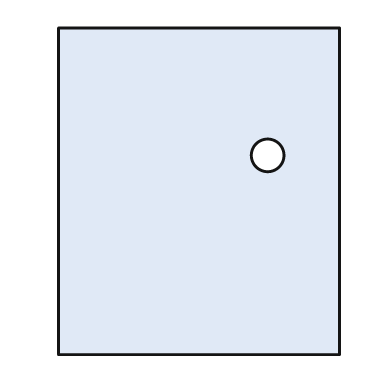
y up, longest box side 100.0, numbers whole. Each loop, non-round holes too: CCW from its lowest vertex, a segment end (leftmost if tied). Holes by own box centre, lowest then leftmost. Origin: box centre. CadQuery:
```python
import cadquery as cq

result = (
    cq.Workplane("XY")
    .moveTo(-43.0, -50.0)
    .lineTo(43.0, -50.0)
    .lineTo(43.0, 50.0)
    .lineTo(-43.0, 50.0)
    .close()
    .moveTo(21.0, 11.0)
    .circle(5.0)
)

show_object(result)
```